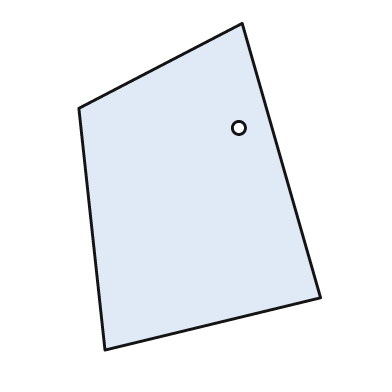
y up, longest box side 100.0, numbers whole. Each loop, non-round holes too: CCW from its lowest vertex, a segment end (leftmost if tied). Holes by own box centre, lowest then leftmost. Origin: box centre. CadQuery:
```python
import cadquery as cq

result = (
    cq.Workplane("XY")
    .moveTo(-29.0, -50.0)
    .lineTo(37.0, -34.0)
    .lineTo(13.0, 50.0)
    .lineTo(-37.0, 24.0)
    .close()
    .moveTo(12.0, 18.0)
    .circle(2.0)
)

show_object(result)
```